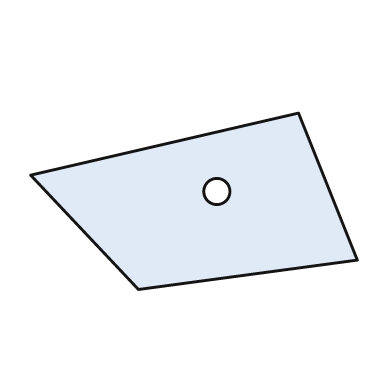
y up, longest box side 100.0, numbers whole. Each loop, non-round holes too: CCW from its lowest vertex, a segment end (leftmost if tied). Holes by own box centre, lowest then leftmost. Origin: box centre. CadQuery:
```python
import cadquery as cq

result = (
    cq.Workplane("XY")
    .moveTo(-17.0, -27.0)
    .lineTo(50.0, -18.0)
    .lineTo(32.0, 27.0)
    .lineTo(-50.0, 8.0)
    .close()
    .moveTo(7.0, 3.0)
    .circle(4.0)
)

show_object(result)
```